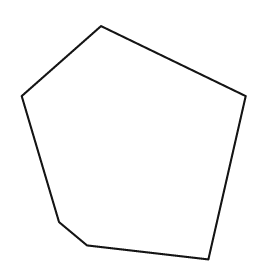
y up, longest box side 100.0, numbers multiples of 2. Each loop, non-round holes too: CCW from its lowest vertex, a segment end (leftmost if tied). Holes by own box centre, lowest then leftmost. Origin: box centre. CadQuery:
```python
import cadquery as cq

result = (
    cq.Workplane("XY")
    .moveTo(32.0, -50.0)
    .lineTo(48.0, 20.0)
    .lineTo(-14.0, 50.0)
    .lineTo(-48.0, 20.0)
    .lineTo(-32.0, -34.0)
    .lineTo(-20.0, -44.0)
    .close()
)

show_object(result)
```